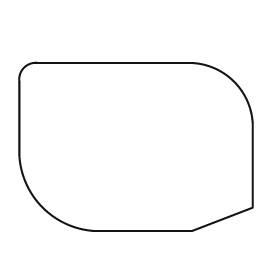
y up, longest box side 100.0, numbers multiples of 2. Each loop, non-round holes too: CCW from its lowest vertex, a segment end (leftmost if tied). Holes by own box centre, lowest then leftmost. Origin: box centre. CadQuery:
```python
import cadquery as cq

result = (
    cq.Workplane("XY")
    .moveTo(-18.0, -36.0)
    .lineTo(24.0, -36.0)
    .lineTo(50.0, -26.0)
    .lineTo(50.0, 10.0)
    .threePointArc((42.0, 28.0), (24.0, 36.0))
    .lineTo(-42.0, 36.0)
    .threePointArc((-48.0, 34.0), (-50.0, 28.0))
    .lineTo(-50.0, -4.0)
    .threePointArc((-40.0, -26.0), (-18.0, -36.0))
    .close()
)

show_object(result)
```